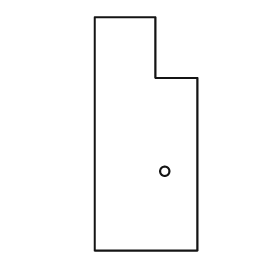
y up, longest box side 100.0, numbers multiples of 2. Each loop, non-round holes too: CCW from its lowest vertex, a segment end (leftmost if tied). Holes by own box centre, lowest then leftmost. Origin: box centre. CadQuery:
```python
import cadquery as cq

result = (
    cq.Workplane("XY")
    .moveTo(-22.0, -50.0)
    .lineTo(22.0, -50.0)
    .lineTo(22.0, 24.0)
    .lineTo(4.0, 24.0)
    .lineTo(4.0, 50.0)
    .lineTo(-22.0, 50.0)
    .close()
    .moveTo(8.0, -16.0)
    .circle(2.0)
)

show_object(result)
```